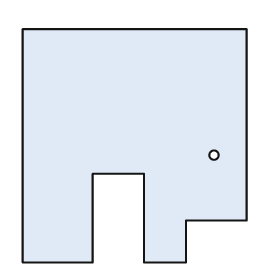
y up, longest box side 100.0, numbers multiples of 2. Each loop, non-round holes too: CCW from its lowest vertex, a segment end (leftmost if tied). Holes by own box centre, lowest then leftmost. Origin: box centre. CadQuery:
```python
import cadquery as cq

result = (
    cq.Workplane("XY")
    .moveTo(-48.0, -50.0)
    .lineTo(-18.0, -50.0)
    .lineTo(-18.0, -12.0)
    .lineTo(4.0, -12.0)
    .lineTo(4.0, -50.0)
    .lineTo(22.0, -50.0)
    .lineTo(22.0, -32.0)
    .lineTo(48.0, -32.0)
    .lineTo(48.0, 50.0)
    .lineTo(-48.0, 50.0)
    .close()
    .moveTo(34.0, -4.0)
    .circle(2.0)
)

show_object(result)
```